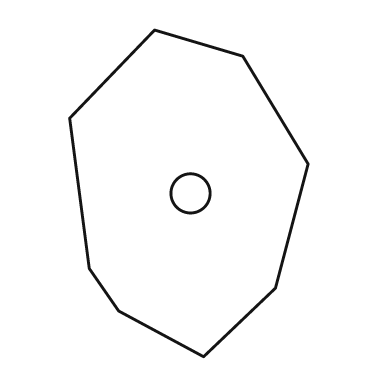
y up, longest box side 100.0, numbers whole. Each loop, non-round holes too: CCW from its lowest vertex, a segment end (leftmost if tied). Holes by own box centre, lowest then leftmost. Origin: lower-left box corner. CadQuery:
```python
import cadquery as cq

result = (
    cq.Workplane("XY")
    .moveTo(41.0, 0.0)
    .lineTo(63.0, 21.0)
    .lineTo(73.0, 59.0)
    .lineTo(53.0, 92.0)
    .lineTo(26.0, 100.0)
    .lineTo(0.0, 73.0)
    .lineTo(6.0, 27.0)
    .lineTo(15.0, 14.0)
    .close()
    .moveTo(37.0, 50.0)
    .circle(6.0)
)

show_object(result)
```